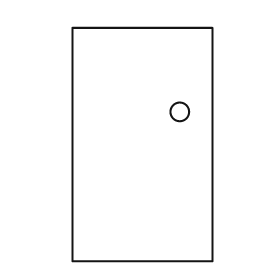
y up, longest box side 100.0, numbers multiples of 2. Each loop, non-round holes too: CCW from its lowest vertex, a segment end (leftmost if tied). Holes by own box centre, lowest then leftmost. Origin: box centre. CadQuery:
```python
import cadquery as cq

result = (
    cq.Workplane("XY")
    .moveTo(-30.0, -50.0)
    .lineTo(30.0, -50.0)
    .lineTo(30.0, 50.0)
    .lineTo(-30.0, 50.0)
    .close()
    .moveTo(16.0, 14.0)
    .circle(4.0)
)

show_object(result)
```